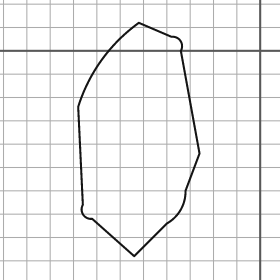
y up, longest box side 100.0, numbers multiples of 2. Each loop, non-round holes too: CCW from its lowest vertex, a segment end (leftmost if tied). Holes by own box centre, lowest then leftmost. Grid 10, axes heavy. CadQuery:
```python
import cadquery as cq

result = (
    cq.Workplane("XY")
    .moveTo(-54.0, -88.0)
    .lineTo(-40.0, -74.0)
    .threePointArc((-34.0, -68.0), (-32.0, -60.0))
    .lineTo(-26.0, -44.0)
    .lineTo(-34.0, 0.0)
    .threePointArc((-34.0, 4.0), (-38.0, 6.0))
    .lineTo(-52.0, 12.0)
    .threePointArc((-68.0, -4.0), (-78.0, -24.0))
    .lineTo(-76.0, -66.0)
    .threePointArc((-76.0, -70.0), (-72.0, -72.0))
    .close()
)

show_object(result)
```